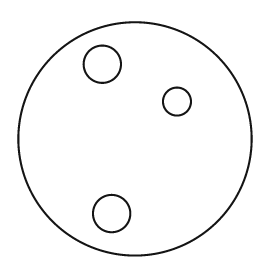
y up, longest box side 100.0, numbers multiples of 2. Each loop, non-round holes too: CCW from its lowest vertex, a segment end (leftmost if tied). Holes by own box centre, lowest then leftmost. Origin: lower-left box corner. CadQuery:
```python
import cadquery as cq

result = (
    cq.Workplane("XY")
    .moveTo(50.0, 50.0)
    .circle(50.0)
    .moveTo(40.0, 18.0)
    .circle(8.0)
    .moveTo(68.0, 66.0)
    .circle(6.0)
    .moveTo(36.0, 82.0)
    .circle(8.0)
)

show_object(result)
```